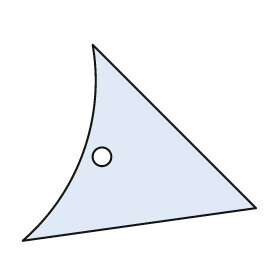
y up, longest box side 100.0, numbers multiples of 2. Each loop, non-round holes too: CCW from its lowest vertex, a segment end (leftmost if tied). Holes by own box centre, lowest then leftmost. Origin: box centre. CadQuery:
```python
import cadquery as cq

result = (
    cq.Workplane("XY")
    .moveTo(-50.0, -42.0)
    .lineTo(50.0, -28.0)
    .lineTo(-20.0, 42.0)
    .threePointArc((-24.0, -4.0), (-50.0, -42.0))
    .close()
    .moveTo(-16.0, -6.0)
    .circle(4.0)
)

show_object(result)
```